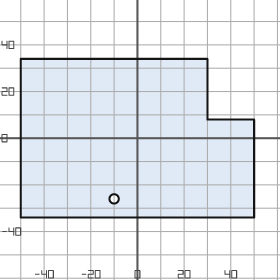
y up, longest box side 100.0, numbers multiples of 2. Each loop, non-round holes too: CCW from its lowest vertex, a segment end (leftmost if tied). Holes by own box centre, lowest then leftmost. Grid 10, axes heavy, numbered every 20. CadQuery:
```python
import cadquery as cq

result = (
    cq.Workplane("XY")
    .moveTo(-50.0, -34.0)
    .lineTo(50.0, -34.0)
    .lineTo(50.0, 8.0)
    .lineTo(30.0, 8.0)
    .lineTo(30.0, 34.0)
    .lineTo(-50.0, 34.0)
    .close()
    .moveTo(-10.0, -26.0)
    .circle(2.0)
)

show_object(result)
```